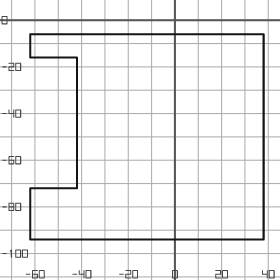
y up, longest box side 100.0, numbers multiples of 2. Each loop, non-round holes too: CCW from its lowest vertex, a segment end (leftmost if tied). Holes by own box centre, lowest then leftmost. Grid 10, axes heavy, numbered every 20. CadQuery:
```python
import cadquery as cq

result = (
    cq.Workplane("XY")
    .moveTo(-62.0, -94.0)
    .lineTo(38.0, -94.0)
    .lineTo(38.0, -6.0)
    .lineTo(-62.0, -6.0)
    .lineTo(-62.0, -16.0)
    .lineTo(-42.0, -16.0)
    .lineTo(-42.0, -72.0)
    .lineTo(-62.0, -72.0)
    .close()
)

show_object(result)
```